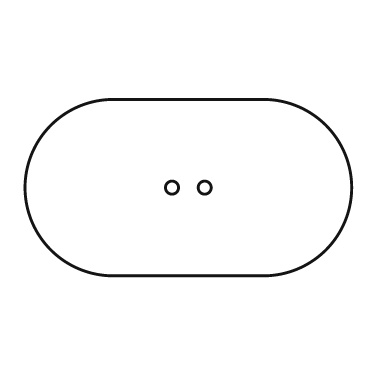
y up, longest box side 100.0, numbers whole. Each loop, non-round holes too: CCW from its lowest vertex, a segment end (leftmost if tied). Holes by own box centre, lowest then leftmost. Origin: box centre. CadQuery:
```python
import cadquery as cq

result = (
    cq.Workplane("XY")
    .moveTo(-23.0, -27.0)
    .lineTo(23.0, -27.0)
    .threePointArc((50.0, 0.0), (23.0, 27.0))
    .lineTo(-23.0, 27.0)
    .threePointArc((-50.0, 0.0), (-23.0, -27.0))
    .close()
    .moveTo(-5.0, 0.0)
    .circle(2.0)
    .moveTo(5.0, 0.0)
    .circle(2.0)
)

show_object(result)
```